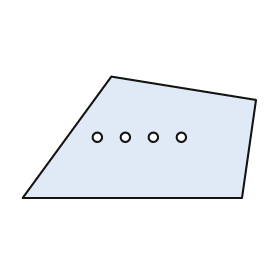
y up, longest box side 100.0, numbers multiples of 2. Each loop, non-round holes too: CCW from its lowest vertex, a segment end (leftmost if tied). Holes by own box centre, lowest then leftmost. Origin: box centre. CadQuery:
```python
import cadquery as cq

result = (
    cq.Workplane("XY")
    .moveTo(-50.0, -26.0)
    .lineTo(44.0, -26.0)
    .lineTo(50.0, 16.0)
    .lineTo(-12.0, 26.0)
    .close()
    .moveTo(-18.0, 0.0)
    .circle(2.0)
    .moveTo(-6.0, 0.0)
    .circle(2.0)
    .moveTo(6.0, 0.0)
    .circle(2.0)
    .moveTo(18.0, 0.0)
    .circle(2.0)
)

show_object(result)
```